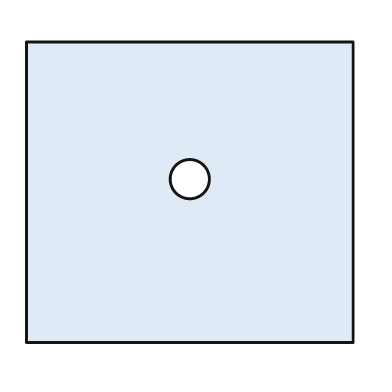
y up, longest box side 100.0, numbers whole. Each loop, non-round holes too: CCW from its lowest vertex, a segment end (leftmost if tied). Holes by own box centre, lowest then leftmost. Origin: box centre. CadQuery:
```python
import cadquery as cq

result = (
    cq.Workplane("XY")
    .moveTo(-50.0, -46.0)
    .lineTo(50.0, -46.0)
    .lineTo(50.0, 46.0)
    .lineTo(-50.0, 46.0)
    .close()
    .moveTo(0.0, 4.0)
    .circle(6.0)
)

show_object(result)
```